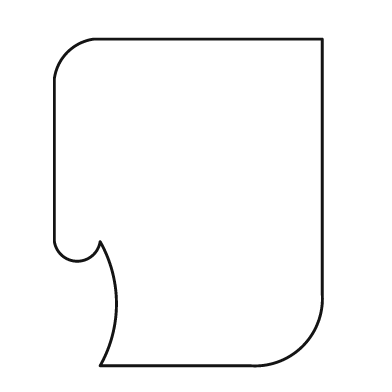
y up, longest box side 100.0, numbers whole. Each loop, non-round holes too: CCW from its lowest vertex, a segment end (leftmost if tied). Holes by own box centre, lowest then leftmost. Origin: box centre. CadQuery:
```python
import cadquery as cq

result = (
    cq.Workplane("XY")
    .moveTo(-27.0, -50.0)
    .lineTo(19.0, -50.0)
    .threePointArc((35.0, -44.0), (41.0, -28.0))
    .lineTo(41.0, 50.0)
    .lineTo(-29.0, 50.0)
    .threePointArc((-37.0, 46.0), (-41.0, 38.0))
    .lineTo(-41.0, -12.0)
    .threePointArc((-34.0, -18.0), (-27.0, -12.0))
    .threePointArc((-22.0, -31.0), (-27.0, -50.0))
    .close()
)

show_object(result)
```